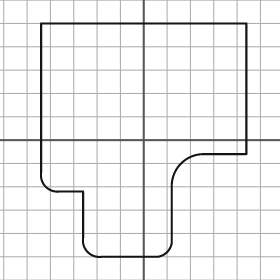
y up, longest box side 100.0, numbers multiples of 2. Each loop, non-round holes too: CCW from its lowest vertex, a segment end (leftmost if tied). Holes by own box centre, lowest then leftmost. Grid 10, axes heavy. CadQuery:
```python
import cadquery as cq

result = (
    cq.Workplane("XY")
    .moveTo(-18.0, -50.0)
    .lineTo(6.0, -50.0)
    .threePointArc((10.0, -48.0), (12.0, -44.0))
    .lineTo(12.0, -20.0)
    .threePointArc((16.0, -10.0), (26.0, -6.0))
    .lineTo(44.0, -6.0)
    .lineTo(44.0, 50.0)
    .lineTo(-44.0, 50.0)
    .lineTo(-44.0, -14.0)
    .threePointArc((-42.0, -20.0), (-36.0, -22.0))
    .lineTo(-26.0, -22.0)
    .lineTo(-26.0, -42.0)
    .threePointArc((-24.0, -48.0), (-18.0, -50.0))
    .close()
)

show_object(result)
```